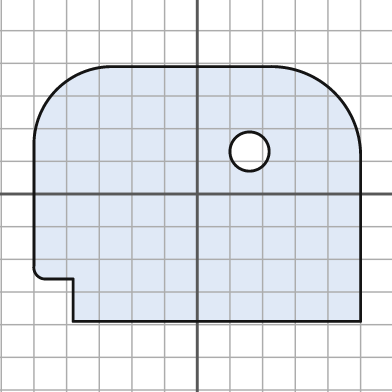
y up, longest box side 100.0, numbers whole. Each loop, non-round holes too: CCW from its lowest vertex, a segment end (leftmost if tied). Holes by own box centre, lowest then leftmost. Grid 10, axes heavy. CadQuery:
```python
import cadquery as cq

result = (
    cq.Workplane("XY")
    .moveTo(-38.0, -39.0)
    .lineTo(50.0, -39.0)
    .lineTo(50.0, 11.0)
    .threePointArc((42.0, 31.0), (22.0, 39.0))
    .lineTo(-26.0, 39.0)
    .threePointArc((-43.0, 32.0), (-50.0, 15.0))
    .lineTo(-50.0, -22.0)
    .threePointArc((-49.0, -25.0), (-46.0, -26.0))
    .lineTo(-38.0, -26.0)
    .close()
    .moveTo(16.0, 13.0)
    .circle(6.0)
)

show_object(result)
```